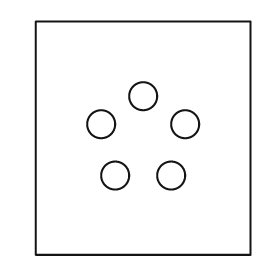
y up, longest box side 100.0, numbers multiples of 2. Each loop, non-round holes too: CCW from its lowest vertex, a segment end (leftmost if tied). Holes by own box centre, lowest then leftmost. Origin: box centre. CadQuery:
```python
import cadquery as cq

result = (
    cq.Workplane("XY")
    .moveTo(-46.0, -50.0)
    .lineTo(46.0, -50.0)
    .lineTo(46.0, 50.0)
    .lineTo(-46.0, 50.0)
    .close()
    .moveTo(-12.0, -16.0)
    .circle(6.0)
    .moveTo(12.0, -16.0)
    .circle(6.0)
    .moveTo(-18.0, 6.0)
    .circle(6.0)
    .moveTo(18.0, 6.0)
    .circle(6.0)
    .moveTo(0.0, 18.0)
    .circle(6.0)
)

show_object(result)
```